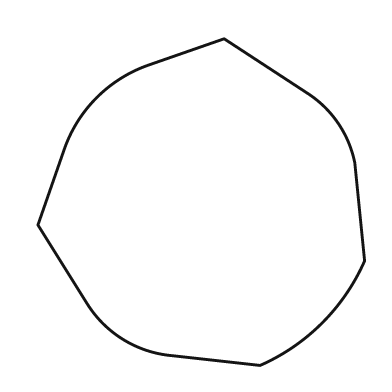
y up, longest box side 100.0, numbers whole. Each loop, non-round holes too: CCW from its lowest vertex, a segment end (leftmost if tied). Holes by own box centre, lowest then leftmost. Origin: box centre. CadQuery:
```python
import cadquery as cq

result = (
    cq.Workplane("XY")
    .moveTo(18.0, -50.0)
    .threePointArc((37.0, -37.0), (50.0, -18.0))
    .lineTo(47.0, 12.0)
    .threePointArc((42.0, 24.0), (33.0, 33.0))
    .lineTo(7.0, 50.0)
    .lineTo(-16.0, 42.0)
    .threePointArc((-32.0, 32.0), (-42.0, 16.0))
    .lineTo(-50.0, -7.0)
    .lineTo(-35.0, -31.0)
    .threePointArc((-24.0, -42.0), (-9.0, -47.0))
    .close()
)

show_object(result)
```